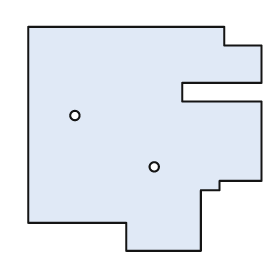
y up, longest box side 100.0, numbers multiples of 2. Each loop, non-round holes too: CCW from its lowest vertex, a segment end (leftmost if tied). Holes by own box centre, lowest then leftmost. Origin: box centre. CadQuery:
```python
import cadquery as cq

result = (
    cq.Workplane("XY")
    .moveTo(-8.0, -48.0)
    .lineTo(24.0, -48.0)
    .lineTo(24.0, -22.0)
    .lineTo(32.0, -22.0)
    .lineTo(32.0, -18.0)
    .lineTo(50.0, -18.0)
    .lineTo(50.0, 16.0)
    .lineTo(16.0, 16.0)
    .lineTo(16.0, 24.0)
    .lineTo(50.0, 24.0)
    .lineTo(50.0, 40.0)
    .lineTo(34.0, 40.0)
    .lineTo(34.0, 48.0)
    .lineTo(-50.0, 48.0)
    .lineTo(-50.0, -36.0)
    .lineTo(-8.0, -36.0)
    .close()
    .moveTo(4.0, -12.0)
    .circle(2.0)
    .moveTo(-30.0, 10.0)
    .circle(2.0)
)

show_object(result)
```